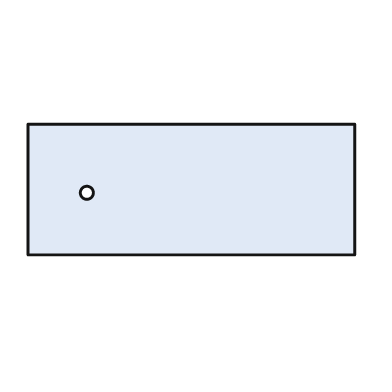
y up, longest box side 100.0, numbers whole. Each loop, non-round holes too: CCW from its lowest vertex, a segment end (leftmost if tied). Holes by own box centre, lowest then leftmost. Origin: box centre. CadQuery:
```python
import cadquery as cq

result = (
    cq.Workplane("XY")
    .moveTo(-50.0, -20.0)
    .lineTo(50.0, -20.0)
    .lineTo(50.0, 20.0)
    .lineTo(-50.0, 20.0)
    .close()
    .moveTo(-32.0, -1.0)
    .circle(2.0)
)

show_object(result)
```